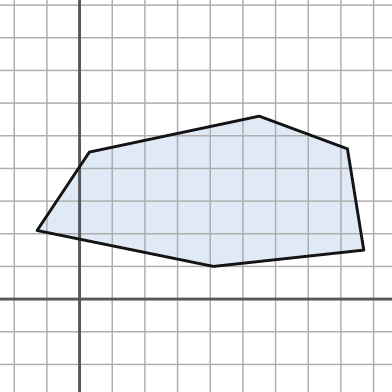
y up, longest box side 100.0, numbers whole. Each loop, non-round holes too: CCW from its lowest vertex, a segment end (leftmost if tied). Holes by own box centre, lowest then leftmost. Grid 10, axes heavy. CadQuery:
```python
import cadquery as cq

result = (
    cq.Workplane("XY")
    .moveTo(41.0, 10.0)
    .lineTo(87.0, 15.0)
    .lineTo(82.0, 46.0)
    .lineTo(55.0, 56.0)
    .lineTo(3.0, 45.0)
    .lineTo(-13.0, 21.0)
    .close()
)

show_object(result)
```